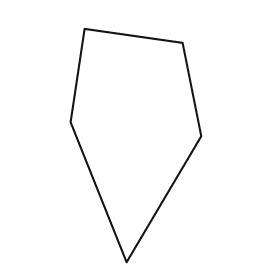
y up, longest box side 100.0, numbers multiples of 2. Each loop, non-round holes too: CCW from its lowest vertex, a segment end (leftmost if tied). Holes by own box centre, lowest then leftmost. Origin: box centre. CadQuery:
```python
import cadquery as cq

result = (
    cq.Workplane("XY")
    .moveTo(-4.0, -50.0)
    .lineTo(28.0, 4.0)
    .lineTo(20.0, 44.0)
    .lineTo(-22.0, 50.0)
    .lineTo(-28.0, 10.0)
    .close()
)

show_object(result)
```